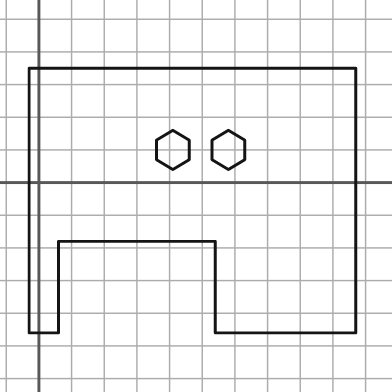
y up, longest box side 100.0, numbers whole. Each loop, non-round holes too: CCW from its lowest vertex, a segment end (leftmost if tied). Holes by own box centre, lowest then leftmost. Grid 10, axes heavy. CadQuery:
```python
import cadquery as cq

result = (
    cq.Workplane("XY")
    .moveTo(-3.0, -46.0)
    .lineTo(6.0, -46.0)
    .lineTo(6.0, -18.0)
    .lineTo(54.0, -18.0)
    .lineTo(54.0, -46.0)
    .lineTo(97.0, -46.0)
    .lineTo(97.0, 35.0)
    .lineTo(-3.0, 35.0)
    .close()
    .moveTo(41.0, 4.0)
    .lineTo(46.0, 7.0)
    .lineTo(46.0, 13.0)
    .lineTo(41.0, 16.0)
    .lineTo(36.0, 13.0)
    .lineTo(36.0, 7.0)
    .close()
    .moveTo(58.0, 4.0)
    .lineTo(63.0, 7.0)
    .lineTo(63.0, 13.0)
    .lineTo(58.0, 16.0)
    .lineTo(53.0, 13.0)
    .lineTo(53.0, 7.0)
    .close()
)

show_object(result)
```